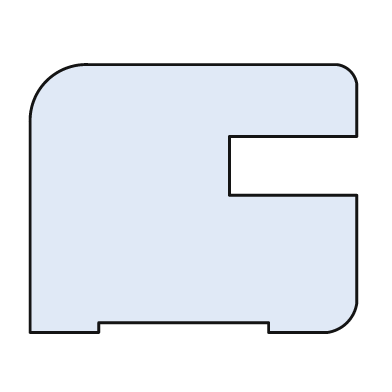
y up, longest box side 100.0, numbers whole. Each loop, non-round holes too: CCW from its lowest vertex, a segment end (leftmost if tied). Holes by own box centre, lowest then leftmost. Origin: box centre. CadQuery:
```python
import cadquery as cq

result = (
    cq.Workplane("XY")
    .moveTo(-50.0, -41.0)
    .lineTo(-29.0, -41.0)
    .lineTo(-29.0, -38.0)
    .lineTo(23.0, -38.0)
    .lineTo(23.0, -41.0)
    .lineTo(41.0, -41.0)
    .threePointArc((47.0, -38.0), (50.0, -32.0))
    .lineTo(50.0, 1.0)
    .lineTo(11.0, 1.0)
    .lineTo(11.0, 19.0)
    .lineTo(50.0, 19.0)
    .lineTo(50.0, 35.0)
    .threePointArc((48.0, 39.0), (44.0, 41.0))
    .lineTo(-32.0, 41.0)
    .threePointArc((-45.0, 36.0), (-50.0, 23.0))
    .close()
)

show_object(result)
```